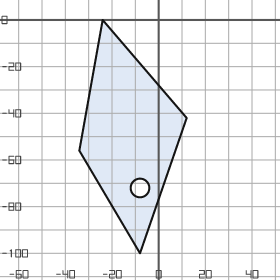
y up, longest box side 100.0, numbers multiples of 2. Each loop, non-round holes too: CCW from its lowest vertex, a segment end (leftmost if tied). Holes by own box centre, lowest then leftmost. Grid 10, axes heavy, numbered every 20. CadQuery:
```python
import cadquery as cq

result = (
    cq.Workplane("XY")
    .moveTo(-8.0, -100.0)
    .lineTo(12.0, -42.0)
    .lineTo(-24.0, 0.0)
    .lineTo(-34.0, -56.0)
    .close()
    .moveTo(-8.0, -72.0)
    .circle(4.0)
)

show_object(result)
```